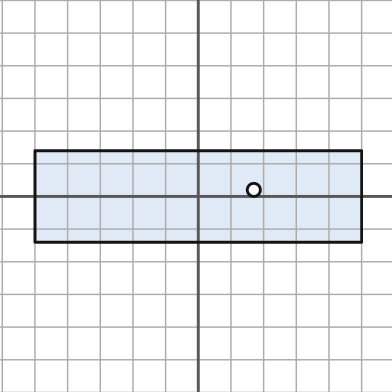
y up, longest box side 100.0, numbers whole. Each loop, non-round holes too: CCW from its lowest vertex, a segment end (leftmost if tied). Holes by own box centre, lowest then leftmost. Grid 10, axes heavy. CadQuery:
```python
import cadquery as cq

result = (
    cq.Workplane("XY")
    .moveTo(-50.0, -14.0)
    .lineTo(50.0, -14.0)
    .lineTo(50.0, 14.0)
    .lineTo(-50.0, 14.0)
    .close()
    .moveTo(17.0, 2.0)
    .circle(2.0)
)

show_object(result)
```